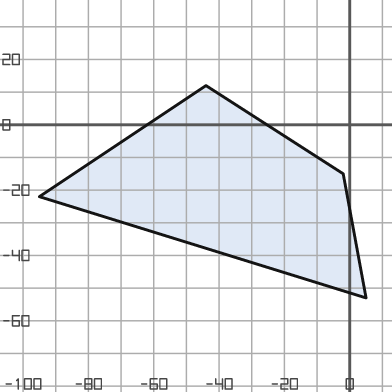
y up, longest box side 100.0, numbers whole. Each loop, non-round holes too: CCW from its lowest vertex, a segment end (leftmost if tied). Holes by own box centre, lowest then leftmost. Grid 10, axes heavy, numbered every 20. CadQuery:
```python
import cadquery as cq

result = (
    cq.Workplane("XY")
    .moveTo(5.0, -53.0)
    .lineTo(-2.0, -15.0)
    .lineTo(-44.0, 12.0)
    .lineTo(-95.0, -22.0)
    .close()
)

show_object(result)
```